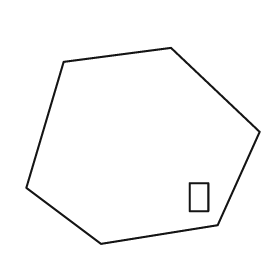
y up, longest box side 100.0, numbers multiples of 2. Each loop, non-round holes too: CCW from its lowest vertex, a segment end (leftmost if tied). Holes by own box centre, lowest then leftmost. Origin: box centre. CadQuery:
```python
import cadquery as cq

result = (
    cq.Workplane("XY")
    .moveTo(-18.0, -42.0)
    .lineTo(32.0, -34.0)
    .lineTo(50.0, 6.0)
    .lineTo(12.0, 42.0)
    .lineTo(-34.0, 36.0)
    .lineTo(-50.0, -18.0)
    .close()
    .moveTo(20.0, -28.0)
    .lineTo(28.0, -28.0)
    .lineTo(28.0, -16.0)
    .lineTo(20.0, -16.0)
    .close()
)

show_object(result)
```